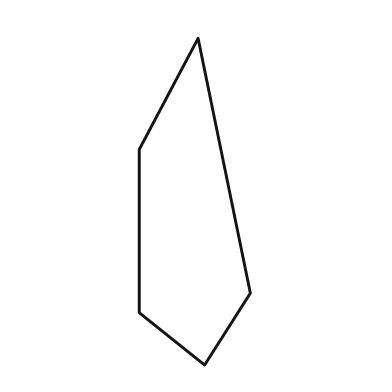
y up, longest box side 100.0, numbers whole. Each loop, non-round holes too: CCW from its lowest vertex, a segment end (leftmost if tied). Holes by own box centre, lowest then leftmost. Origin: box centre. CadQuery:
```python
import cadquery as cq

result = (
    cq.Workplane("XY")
    .moveTo(3.0, -50.0)
    .lineTo(17.0, -28.0)
    .lineTo(1.0, 50.0)
    .lineTo(-17.0, 16.0)
    .lineTo(-17.0, -34.0)
    .close()
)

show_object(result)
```